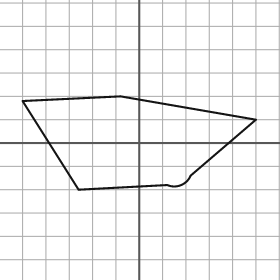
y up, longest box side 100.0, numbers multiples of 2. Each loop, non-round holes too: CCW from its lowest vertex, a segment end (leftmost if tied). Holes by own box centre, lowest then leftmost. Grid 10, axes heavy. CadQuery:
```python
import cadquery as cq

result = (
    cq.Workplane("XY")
    .moveTo(-26.0, -20.0)
    .lineTo(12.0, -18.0)
    .threePointArc((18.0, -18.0), (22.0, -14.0))
    .lineTo(50.0, 10.0)
    .lineTo(-8.0, 20.0)
    .lineTo(-50.0, 18.0)
    .close()
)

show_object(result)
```